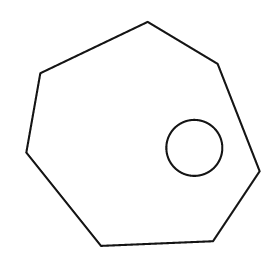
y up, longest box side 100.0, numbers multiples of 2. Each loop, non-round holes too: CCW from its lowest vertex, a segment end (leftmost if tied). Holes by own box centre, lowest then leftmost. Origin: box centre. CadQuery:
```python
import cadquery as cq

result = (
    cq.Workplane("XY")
    .moveTo(-18.0, -48.0)
    .lineTo(30.0, -46.0)
    .lineTo(50.0, -16.0)
    .lineTo(32.0, 30.0)
    .lineTo(2.0, 48.0)
    .lineTo(-44.0, 26.0)
    .lineTo(-50.0, -8.0)
    .close()
    .moveTo(22.0, -6.0)
    .circle(12.0)
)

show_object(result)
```